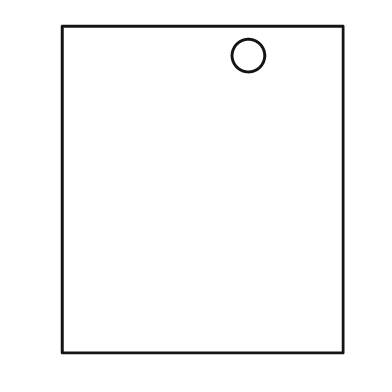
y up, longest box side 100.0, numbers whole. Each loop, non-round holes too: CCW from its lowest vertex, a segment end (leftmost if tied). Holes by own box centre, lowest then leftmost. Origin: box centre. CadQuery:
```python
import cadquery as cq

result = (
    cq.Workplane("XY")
    .moveTo(-43.0, -50.0)
    .lineTo(43.0, -50.0)
    .lineTo(43.0, 50.0)
    .lineTo(-43.0, 50.0)
    .close()
    .moveTo(14.0, 41.0)
    .circle(5.0)
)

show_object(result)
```